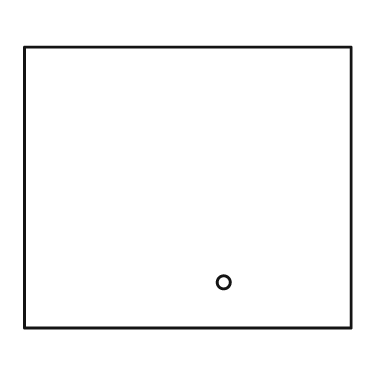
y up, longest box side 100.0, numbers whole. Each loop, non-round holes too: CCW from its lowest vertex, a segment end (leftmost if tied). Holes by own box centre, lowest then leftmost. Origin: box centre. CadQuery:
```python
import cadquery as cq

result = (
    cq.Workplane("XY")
    .moveTo(-50.0, -43.0)
    .lineTo(50.0, -43.0)
    .lineTo(50.0, 43.0)
    .lineTo(-50.0, 43.0)
    .close()
    .moveTo(11.0, -29.0)
    .circle(2.0)
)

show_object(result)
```